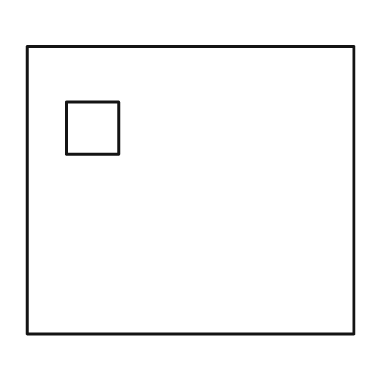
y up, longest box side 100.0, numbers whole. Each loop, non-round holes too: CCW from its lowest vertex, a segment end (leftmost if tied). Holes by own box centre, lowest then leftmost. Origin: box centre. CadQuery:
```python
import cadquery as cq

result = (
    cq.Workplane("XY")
    .moveTo(-50.0, -44.0)
    .lineTo(50.0, -44.0)
    .lineTo(50.0, 44.0)
    .lineTo(-50.0, 44.0)
    .close()
    .moveTo(-38.0, 11.0)
    .lineTo(-22.0, 11.0)
    .lineTo(-22.0, 27.0)
    .lineTo(-38.0, 27.0)
    .close()
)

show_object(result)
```